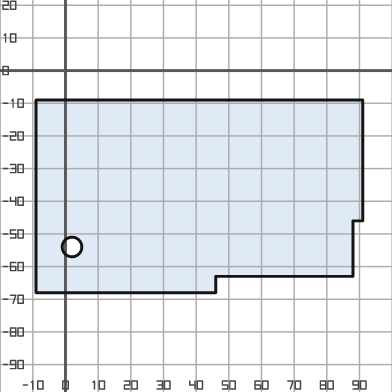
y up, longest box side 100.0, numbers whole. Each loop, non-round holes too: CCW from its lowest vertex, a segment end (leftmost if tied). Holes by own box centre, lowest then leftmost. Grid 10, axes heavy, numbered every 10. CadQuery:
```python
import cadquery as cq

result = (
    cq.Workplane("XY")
    .moveTo(-9.0, -68.0)
    .lineTo(46.0, -68.0)
    .lineTo(46.0, -63.0)
    .lineTo(88.0, -63.0)
    .lineTo(88.0, -46.0)
    .lineTo(91.0, -46.0)
    .lineTo(91.0, -9.0)
    .lineTo(-9.0, -9.0)
    .close()
    .moveTo(2.0, -54.0)
    .circle(3.0)
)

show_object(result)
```